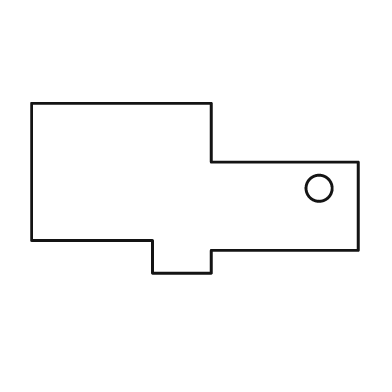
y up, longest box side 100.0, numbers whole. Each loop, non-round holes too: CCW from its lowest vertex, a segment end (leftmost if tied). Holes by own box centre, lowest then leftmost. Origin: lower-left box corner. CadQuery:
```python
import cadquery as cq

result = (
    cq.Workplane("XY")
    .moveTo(37.0, 0.0)
    .lineTo(55.0, 0.0)
    .lineTo(55.0, 7.0)
    .lineTo(100.0, 7.0)
    .lineTo(100.0, 34.0)
    .lineTo(55.0, 34.0)
    .lineTo(55.0, 52.0)
    .lineTo(0.0, 52.0)
    .lineTo(0.0, 10.0)
    .lineTo(37.0, 10.0)
    .close()
    .moveTo(88.0, 26.0)
    .circle(4.0)
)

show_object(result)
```